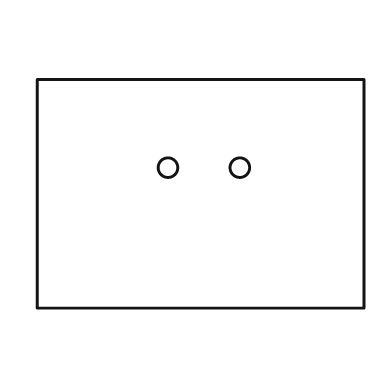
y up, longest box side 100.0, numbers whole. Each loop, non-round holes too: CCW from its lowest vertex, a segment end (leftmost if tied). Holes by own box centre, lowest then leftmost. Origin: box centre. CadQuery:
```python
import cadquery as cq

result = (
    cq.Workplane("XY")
    .moveTo(-50.0, -35.0)
    .lineTo(50.0, -35.0)
    .lineTo(50.0, 35.0)
    .lineTo(-50.0, 35.0)
    .close()
    .moveTo(-10.0, 8.0)
    .circle(3.0)
    .moveTo(12.0, 8.0)
    .circle(3.0)
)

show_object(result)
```